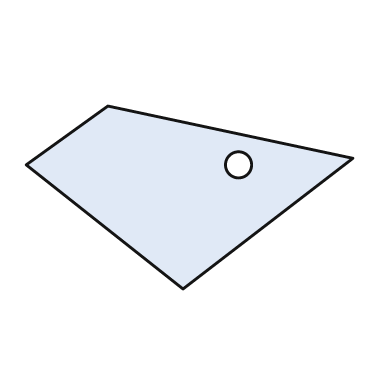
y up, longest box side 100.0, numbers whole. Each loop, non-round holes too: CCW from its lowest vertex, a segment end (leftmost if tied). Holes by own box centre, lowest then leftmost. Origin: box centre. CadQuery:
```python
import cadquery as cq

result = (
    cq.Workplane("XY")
    .moveTo(-2.0, -28.0)
    .lineTo(50.0, 12.0)
    .lineTo(-25.0, 28.0)
    .lineTo(-50.0, 10.0)
    .close()
    .moveTo(15.0, 10.0)
    .circle(4.0)
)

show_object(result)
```